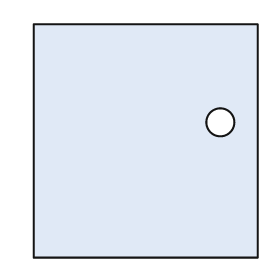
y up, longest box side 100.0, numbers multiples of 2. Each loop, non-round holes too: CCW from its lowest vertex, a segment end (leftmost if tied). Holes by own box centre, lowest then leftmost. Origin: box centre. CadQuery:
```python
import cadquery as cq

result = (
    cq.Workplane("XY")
    .moveTo(-48.0, -50.0)
    .lineTo(48.0, -50.0)
    .lineTo(48.0, 50.0)
    .lineTo(-48.0, 50.0)
    .close()
    .moveTo(32.0, 8.0)
    .circle(6.0)
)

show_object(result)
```